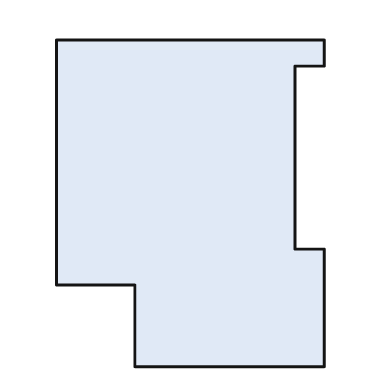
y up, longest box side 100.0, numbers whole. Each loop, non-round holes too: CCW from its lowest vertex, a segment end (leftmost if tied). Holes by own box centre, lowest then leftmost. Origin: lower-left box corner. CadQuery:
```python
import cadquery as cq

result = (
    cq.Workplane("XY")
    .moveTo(24.0, 0.0)
    .lineTo(82.0, 0.0)
    .lineTo(82.0, 36.0)
    .lineTo(73.0, 36.0)
    .lineTo(73.0, 92.0)
    .lineTo(82.0, 92.0)
    .lineTo(82.0, 100.0)
    .lineTo(0.0, 100.0)
    .lineTo(0.0, 25.0)
    .lineTo(24.0, 25.0)
    .close()
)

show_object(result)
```